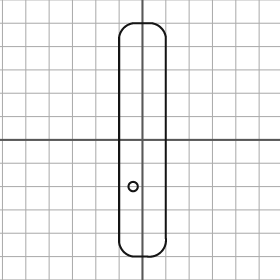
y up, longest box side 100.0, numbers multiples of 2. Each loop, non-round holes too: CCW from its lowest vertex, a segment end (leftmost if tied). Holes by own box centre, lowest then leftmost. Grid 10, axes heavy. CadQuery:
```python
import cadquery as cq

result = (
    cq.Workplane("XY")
    .moveTo(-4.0, -50.0)
    .lineTo(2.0, -50.0)
    .threePointArc((8.0, -48.0), (10.0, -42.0))
    .lineTo(10.0, 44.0)
    .threePointArc((8.0, 48.0), (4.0, 50.0))
    .lineTo(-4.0, 50.0)
    .threePointArc((-8.0, 48.0), (-10.0, 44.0))
    .lineTo(-10.0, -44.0)
    .threePointArc((-8.0, -48.0), (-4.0, -50.0))
    .close()
    .moveTo(-4.0, -20.0)
    .circle(2.0)
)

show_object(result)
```